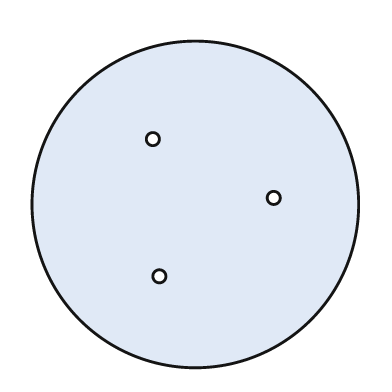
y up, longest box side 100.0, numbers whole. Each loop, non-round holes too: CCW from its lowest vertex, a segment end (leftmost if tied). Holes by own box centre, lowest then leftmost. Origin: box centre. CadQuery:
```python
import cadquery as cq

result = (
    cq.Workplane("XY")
    .moveTo(0.0, 0.0)
    .circle(50.0)
    .moveTo(-11.0, -22.0)
    .circle(2.0)
    .moveTo(24.0, 2.0)
    .circle(2.0)
    .moveTo(-13.0, 20.0)
    .circle(2.0)
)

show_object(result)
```